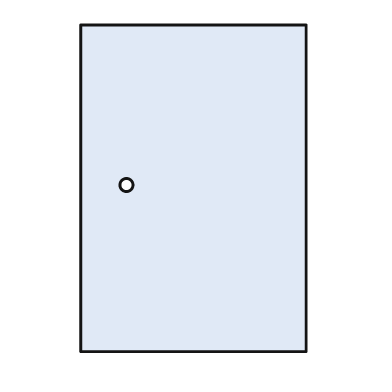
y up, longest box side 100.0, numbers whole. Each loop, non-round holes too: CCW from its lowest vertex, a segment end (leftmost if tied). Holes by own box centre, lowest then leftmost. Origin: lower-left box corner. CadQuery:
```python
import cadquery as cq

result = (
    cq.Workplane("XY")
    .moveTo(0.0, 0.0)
    .lineTo(69.0, 0.0)
    .lineTo(69.0, 100.0)
    .lineTo(0.0, 100.0)
    .close()
    .moveTo(14.0, 51.0)
    .circle(2.0)
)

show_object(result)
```